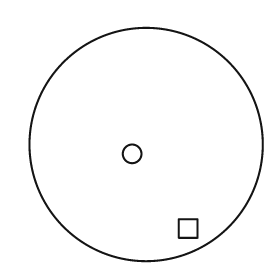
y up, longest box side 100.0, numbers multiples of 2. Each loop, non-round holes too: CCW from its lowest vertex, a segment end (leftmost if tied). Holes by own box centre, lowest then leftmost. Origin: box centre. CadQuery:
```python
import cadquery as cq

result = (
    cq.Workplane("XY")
    .moveTo(0.0, 0.0)
    .circle(50.0)
    .moveTo(14.0, -40.0)
    .lineTo(22.0, -40.0)
    .lineTo(22.0, -32.0)
    .lineTo(14.0, -32.0)
    .close()
    .moveTo(-6.0, -4.0)
    .circle(4.0)
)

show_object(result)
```